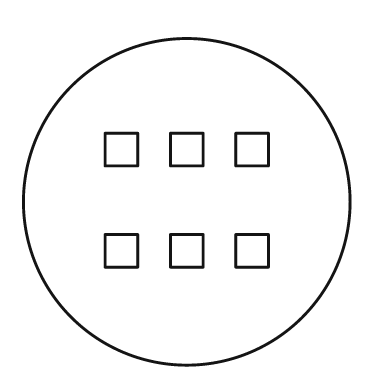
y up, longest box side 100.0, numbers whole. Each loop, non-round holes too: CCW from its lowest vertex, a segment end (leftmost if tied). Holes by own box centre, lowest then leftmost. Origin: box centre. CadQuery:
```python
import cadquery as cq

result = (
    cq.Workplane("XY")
    .moveTo(0.0, 0.0)
    .circle(50.0)
    .moveTo(-25.0, -20.0)
    .lineTo(-15.0, -20.0)
    .lineTo(-15.0, -10.0)
    .lineTo(-25.0, -10.0)
    .close()
    .moveTo(-5.0, -20.0)
    .lineTo(5.0, -20.0)
    .lineTo(5.0, -10.0)
    .lineTo(-5.0, -10.0)
    .close()
    .moveTo(15.0, -20.0)
    .lineTo(25.0, -20.0)
    .lineTo(25.0, -10.0)
    .lineTo(15.0, -10.0)
    .close()
    .moveTo(-25.0, 11.0)
    .lineTo(-15.0, 11.0)
    .lineTo(-15.0, 21.0)
    .lineTo(-25.0, 21.0)
    .close()
    .moveTo(-5.0, 11.0)
    .lineTo(5.0, 11.0)
    .lineTo(5.0, 21.0)
    .lineTo(-5.0, 21.0)
    .close()
    .moveTo(15.0, 11.0)
    .lineTo(25.0, 11.0)
    .lineTo(25.0, 21.0)
    .lineTo(15.0, 21.0)
    .close()
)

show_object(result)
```